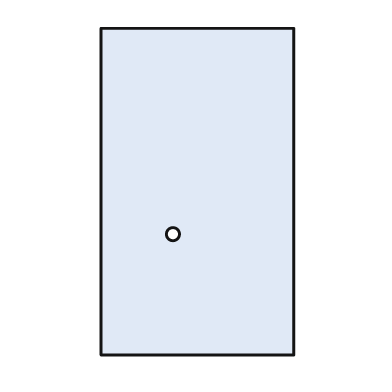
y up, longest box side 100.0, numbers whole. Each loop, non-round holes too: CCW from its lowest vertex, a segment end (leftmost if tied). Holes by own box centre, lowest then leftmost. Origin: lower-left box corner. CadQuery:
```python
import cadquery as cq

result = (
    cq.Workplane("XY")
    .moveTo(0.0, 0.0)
    .lineTo(59.0, 0.0)
    .lineTo(59.0, 100.0)
    .lineTo(0.0, 100.0)
    .close()
    .moveTo(22.0, 37.0)
    .circle(2.0)
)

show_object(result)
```